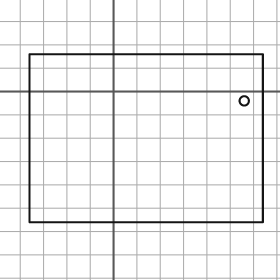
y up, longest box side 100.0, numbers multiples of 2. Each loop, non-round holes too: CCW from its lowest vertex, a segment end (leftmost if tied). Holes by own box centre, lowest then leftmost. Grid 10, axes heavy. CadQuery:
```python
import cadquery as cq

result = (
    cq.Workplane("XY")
    .moveTo(-36.0, -56.0)
    .lineTo(64.0, -56.0)
    .lineTo(64.0, 16.0)
    .lineTo(-36.0, 16.0)
    .close()
    .moveTo(56.0, -4.0)
    .circle(2.0)
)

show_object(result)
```